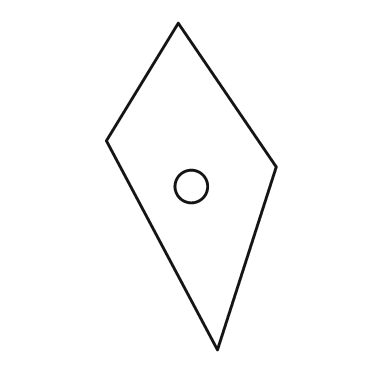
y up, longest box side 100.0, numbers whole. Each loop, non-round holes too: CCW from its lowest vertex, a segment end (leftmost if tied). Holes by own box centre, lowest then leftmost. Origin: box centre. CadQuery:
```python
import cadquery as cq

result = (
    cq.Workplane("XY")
    .moveTo(8.0, -50.0)
    .lineTo(26.0, 6.0)
    .lineTo(-4.0, 50.0)
    .lineTo(-26.0, 14.0)
    .close()
    .moveTo(0.0, 0.0)
    .circle(5.0)
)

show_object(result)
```